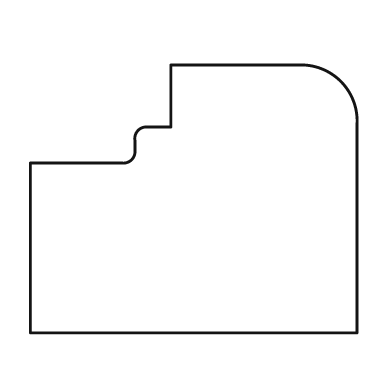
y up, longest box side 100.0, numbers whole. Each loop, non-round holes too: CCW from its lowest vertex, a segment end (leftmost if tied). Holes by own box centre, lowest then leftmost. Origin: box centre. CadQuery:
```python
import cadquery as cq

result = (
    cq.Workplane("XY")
    .moveTo(-50.0, -41.0)
    .lineTo(50.0, -41.0)
    .lineTo(50.0, 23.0)
    .threePointArc((45.0, 36.0), (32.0, 41.0))
    .lineTo(-7.0, 41.0)
    .lineTo(-7.0, 22.0)
    .lineTo(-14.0, 22.0)
    .threePointArc((-17.0, 21.0), (-18.0, 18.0))
    .lineTo(-18.0, 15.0)
    .threePointArc((-19.0, 12.0), (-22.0, 11.0))
    .lineTo(-50.0, 11.0)
    .close()
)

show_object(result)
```